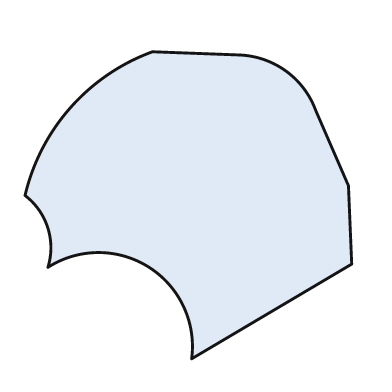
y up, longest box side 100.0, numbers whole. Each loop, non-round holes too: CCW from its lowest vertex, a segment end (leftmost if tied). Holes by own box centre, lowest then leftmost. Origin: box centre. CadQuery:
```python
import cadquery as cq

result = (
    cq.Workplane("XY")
    .moveTo(1.0, -47.0)
    .lineTo(50.0, -18.0)
    .lineTo(49.0, 6.0)
    .lineTo(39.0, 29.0)
    .threePointArc((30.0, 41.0), (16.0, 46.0))
    .lineTo(-11.0, 47.0)
    .threePointArc((-36.0, 30.0), (-50.0, 3.0))
    .threePointArc((-43.0, -7.0), (-43.0, -19.0))
    .threePointArc((-12.0, -19.0), (1.0, -47.0))
    .close()
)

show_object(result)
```